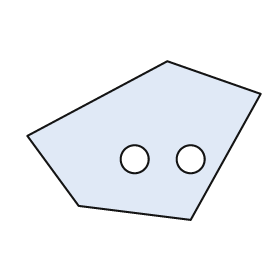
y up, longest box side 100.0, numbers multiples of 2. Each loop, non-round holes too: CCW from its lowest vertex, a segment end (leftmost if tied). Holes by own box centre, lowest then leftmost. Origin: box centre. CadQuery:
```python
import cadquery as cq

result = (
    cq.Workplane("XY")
    .moveTo(20.0, -34.0)
    .lineTo(50.0, 20.0)
    .lineTo(10.0, 34.0)
    .lineTo(-50.0, 2.0)
    .lineTo(-28.0, -28.0)
    .close()
    .moveTo(-4.0, -8.0)
    .circle(6.0)
    .moveTo(20.0, -8.0)
    .circle(6.0)
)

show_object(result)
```